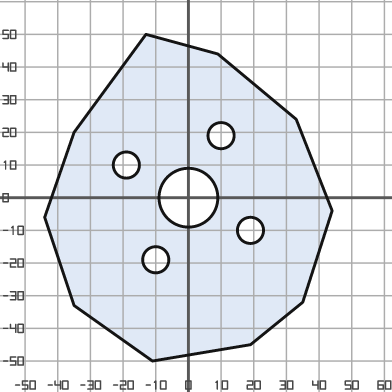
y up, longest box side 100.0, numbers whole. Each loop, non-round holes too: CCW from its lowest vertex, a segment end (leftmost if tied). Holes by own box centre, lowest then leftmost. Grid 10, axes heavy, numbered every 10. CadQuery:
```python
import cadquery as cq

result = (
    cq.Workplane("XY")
    .moveTo(-11.0, -50.0)
    .lineTo(19.0, -45.0)
    .lineTo(35.0, -32.0)
    .lineTo(44.0, -4.0)
    .lineTo(33.0, 24.0)
    .lineTo(9.0, 44.0)
    .lineTo(-13.0, 50.0)
    .lineTo(-35.0, 20.0)
    .lineTo(-44.0, -6.0)
    .lineTo(-35.0, -33.0)
    .close()
    .moveTo(-10.0, -19.0)
    .circle(4.0)
    .moveTo(19.0, -10.0)
    .circle(4.0)
    .moveTo(0.0, 0.0)
    .circle(9.0)
    .moveTo(-19.0, 10.0)
    .circle(4.0)
    .moveTo(10.0, 19.0)
    .circle(4.0)
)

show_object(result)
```